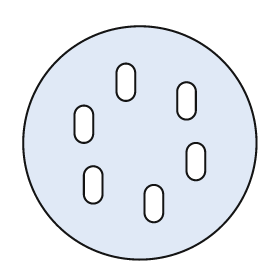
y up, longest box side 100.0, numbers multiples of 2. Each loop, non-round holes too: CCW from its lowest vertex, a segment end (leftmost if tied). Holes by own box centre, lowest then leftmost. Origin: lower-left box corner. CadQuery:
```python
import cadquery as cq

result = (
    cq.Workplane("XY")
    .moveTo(50.0, 50.0)
    .circle(50.0)
    .moveTo(52.0, 20.0)
    .threePointArc((56.0, 16.0), (60.0, 20.0))
    .lineTo(60.0, 28.0)
    .threePointArc((56.0, 32.0), (52.0, 28.0))
    .close()
    .moveTo(26.0, 28.0)
    .threePointArc((30.0, 24.0), (34.0, 28.0))
    .lineTo(34.0, 36.0)
    .threePointArc((30.0, 40.0), (26.0, 36.0))
    .close()
    .moveTo(70.0, 38.0)
    .threePointArc((74.0, 34.0), (78.0, 38.0))
    .lineTo(78.0, 46.0)
    .threePointArc((74.0, 50.0), (70.0, 46.0))
    .close()
    .moveTo(22.0, 54.0)
    .threePointArc((26.0, 50.0), (30.0, 54.0))
    .lineTo(30.0, 62.0)
    .threePointArc((26.0, 66.0), (22.0, 62.0))
    .close()
    .moveTo(66.0, 64.0)
    .threePointArc((70.0, 60.0), (74.0, 64.0))
    .lineTo(74.0, 72.0)
    .threePointArc((70.0, 76.0), (66.0, 72.0))
    .close()
    .moveTo(40.0, 72.0)
    .threePointArc((44.0, 68.0), (48.0, 72.0))
    .lineTo(48.0, 80.0)
    .threePointArc((44.0, 84.0), (40.0, 80.0))
    .close()
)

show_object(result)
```